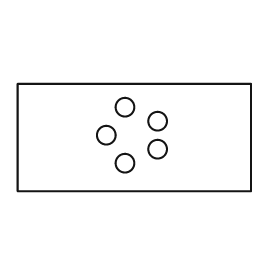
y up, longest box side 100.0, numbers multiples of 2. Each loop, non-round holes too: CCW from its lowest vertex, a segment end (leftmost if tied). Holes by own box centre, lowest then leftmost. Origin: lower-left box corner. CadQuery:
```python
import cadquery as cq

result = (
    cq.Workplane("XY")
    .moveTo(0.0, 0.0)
    .lineTo(100.0, 0.0)
    .lineTo(100.0, 46.0)
    .lineTo(0.0, 46.0)
    .close()
    .moveTo(46.0, 12.0)
    .circle(4.0)
    .moveTo(60.0, 18.0)
    .circle(4.0)
    .moveTo(38.0, 24.0)
    .circle(4.0)
    .moveTo(60.0, 30.0)
    .circle(4.0)
    .moveTo(46.0, 36.0)
    .circle(4.0)
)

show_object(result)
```